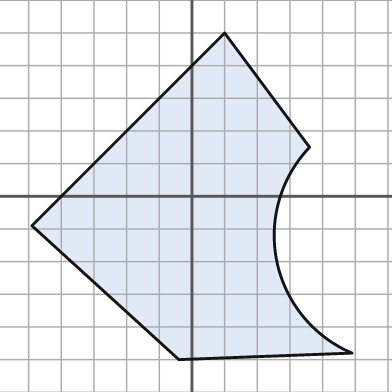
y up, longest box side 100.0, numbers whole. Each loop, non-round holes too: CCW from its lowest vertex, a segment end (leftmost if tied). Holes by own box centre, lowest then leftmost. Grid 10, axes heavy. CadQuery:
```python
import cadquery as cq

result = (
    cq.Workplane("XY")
    .moveTo(-4.0, -50.0)
    .lineTo(49.0, -48.0)
    .threePointArc((26.0, -20.0), (36.0, 15.0))
    .lineTo(10.0, 50.0)
    .lineTo(-49.0, -9.0)
    .close()
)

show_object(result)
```